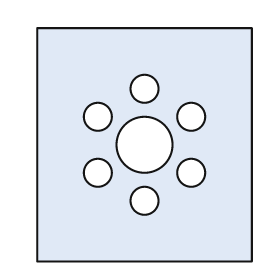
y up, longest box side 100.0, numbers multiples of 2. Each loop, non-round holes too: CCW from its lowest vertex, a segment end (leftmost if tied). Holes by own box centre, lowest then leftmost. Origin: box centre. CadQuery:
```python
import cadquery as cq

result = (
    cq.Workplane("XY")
    .moveTo(-46.0, -50.0)
    .lineTo(46.0, -50.0)
    .lineTo(46.0, 50.0)
    .lineTo(-46.0, 50.0)
    .close()
    .moveTo(0.0, -24.0)
    .circle(6.0)
    .moveTo(-20.0, -12.0)
    .circle(6.0)
    .moveTo(20.0, -12.0)
    .circle(6.0)
    .moveTo(0.0, 0.0)
    .circle(12.0)
    .moveTo(-20.0, 12.0)
    .circle(6.0)
    .moveTo(20.0, 12.0)
    .circle(6.0)
    .moveTo(0.0, 24.0)
    .circle(6.0)
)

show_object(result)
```